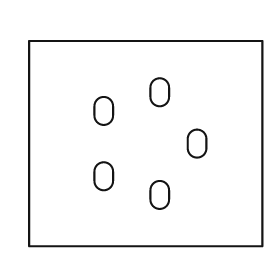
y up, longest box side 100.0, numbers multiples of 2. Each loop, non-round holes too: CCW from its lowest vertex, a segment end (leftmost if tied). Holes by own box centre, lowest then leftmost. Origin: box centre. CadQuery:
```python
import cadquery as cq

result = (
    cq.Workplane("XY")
    .moveTo(-50.0, -44.0)
    .lineTo(50.0, -44.0)
    .lineTo(50.0, 44.0)
    .lineTo(-50.0, 44.0)
    .close()
    .moveTo(2.0, -24.0)
    .threePointArc((6.0, -28.0), (10.0, -24.0))
    .lineTo(10.0, -20.0)
    .threePointArc((6.0, -16.0), (2.0, -20.0))
    .close()
    .moveTo(-22.0, -16.0)
    .threePointArc((-18.0, -20.0), (-14.0, -16.0))
    .lineTo(-14.0, -12.0)
    .threePointArc((-18.0, -8.0), (-22.0, -12.0))
    .close()
    .moveTo(18.0, -2.0)
    .threePointArc((22.0, -6.0), (26.0, -2.0))
    .lineTo(26.0, 2.0)
    .threePointArc((22.0, 6.0), (18.0, 2.0))
    .close()
    .moveTo(-22.0, 12.0)
    .threePointArc((-18.0, 8.0), (-14.0, 12.0))
    .lineTo(-14.0, 16.0)
    .threePointArc((-18.0, 20.0), (-22.0, 16.0))
    .close()
    .moveTo(2.0, 20.0)
    .threePointArc((6.0, 16.0), (10.0, 20.0))
    .lineTo(10.0, 24.0)
    .threePointArc((6.0, 28.0), (2.0, 24.0))
    .close()
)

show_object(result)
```